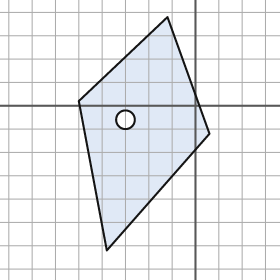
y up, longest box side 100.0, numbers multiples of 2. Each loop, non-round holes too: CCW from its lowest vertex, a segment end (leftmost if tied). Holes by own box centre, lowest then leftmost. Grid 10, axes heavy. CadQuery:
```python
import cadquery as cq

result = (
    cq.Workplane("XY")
    .moveTo(-38.0, -62.0)
    .lineTo(6.0, -12.0)
    .lineTo(-12.0, 38.0)
    .lineTo(-50.0, 2.0)
    .close()
    .moveTo(-30.0, -6.0)
    .circle(4.0)
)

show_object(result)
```